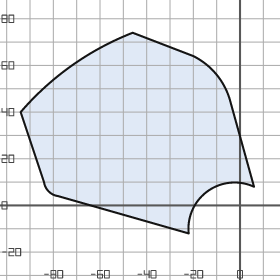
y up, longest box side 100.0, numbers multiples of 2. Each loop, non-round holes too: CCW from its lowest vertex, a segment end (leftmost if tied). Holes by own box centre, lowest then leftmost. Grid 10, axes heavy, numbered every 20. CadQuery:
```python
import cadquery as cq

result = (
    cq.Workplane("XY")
    .moveTo(-22.0, -12.0)
    .threePointArc((-14.0, 6.0), (6.0, 8.0))
    .lineTo(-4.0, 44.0)
    .threePointArc((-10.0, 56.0), (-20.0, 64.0))
    .lineTo(-46.0, 74.0)
    .threePointArc((-72.0, 60.0), (-94.0, 40.0))
    .lineTo(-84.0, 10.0)
    .threePointArc((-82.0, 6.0), (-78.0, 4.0))
    .close()
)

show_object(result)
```